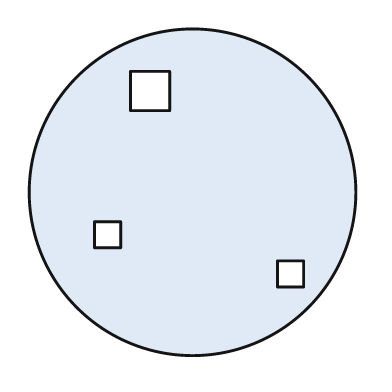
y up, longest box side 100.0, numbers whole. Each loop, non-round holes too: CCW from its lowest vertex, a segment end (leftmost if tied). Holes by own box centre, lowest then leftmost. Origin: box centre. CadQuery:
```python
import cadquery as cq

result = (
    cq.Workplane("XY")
    .moveTo(0.0, 0.0)
    .circle(50.0)
    .moveTo(26.0, -29.0)
    .lineTo(34.0, -29.0)
    .lineTo(34.0, -21.0)
    .lineTo(26.0, -21.0)
    .close()
    .moveTo(-30.0, -17.0)
    .lineTo(-22.0, -17.0)
    .lineTo(-22.0, -9.0)
    .lineTo(-30.0, -9.0)
    .close()
    .moveTo(-19.0, 25.0)
    .lineTo(-7.0, 25.0)
    .lineTo(-7.0, 37.0)
    .lineTo(-19.0, 37.0)
    .close()
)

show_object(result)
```